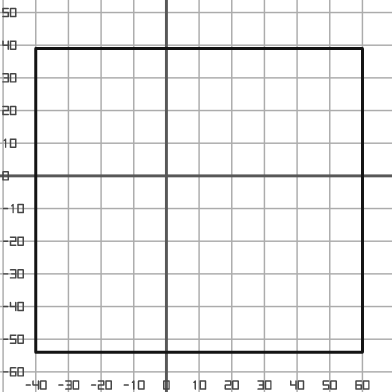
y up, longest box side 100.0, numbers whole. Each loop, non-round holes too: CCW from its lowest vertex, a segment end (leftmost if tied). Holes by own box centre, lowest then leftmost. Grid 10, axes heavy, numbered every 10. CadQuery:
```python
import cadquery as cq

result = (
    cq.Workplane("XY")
    .moveTo(-40.0, -54.0)
    .lineTo(60.0, -54.0)
    .lineTo(60.0, 39.0)
    .lineTo(-40.0, 39.0)
    .close()
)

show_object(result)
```